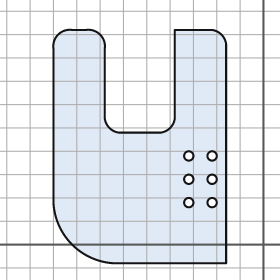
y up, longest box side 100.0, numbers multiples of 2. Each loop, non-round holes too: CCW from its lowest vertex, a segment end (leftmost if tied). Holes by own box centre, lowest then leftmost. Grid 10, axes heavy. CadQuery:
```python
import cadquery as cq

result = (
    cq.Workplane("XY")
    .moveTo(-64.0, -8.0)
    .lineTo(-16.0, -8.0)
    .lineTo(-16.0, 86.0)
    .threePointArc((-18.0, 90.0), (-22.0, 92.0))
    .lineTo(-38.0, 92.0)
    .lineTo(-38.0, 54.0)
    .threePointArc((-40.0, 50.0), (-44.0, 48.0))
    .lineTo(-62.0, 48.0)
    .threePointArc((-66.0, 50.0), (-68.0, 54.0))
    .lineTo(-68.0, 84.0)
    .threePointArc((-70.0, 90.0), (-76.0, 92.0))
    .lineTo(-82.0, 92.0)
    .threePointArc((-88.0, 90.0), (-90.0, 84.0))
    .lineTo(-90.0, 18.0)
    .threePointArc((-82.0, 0.0), (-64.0, -8.0))
    .close()
    .moveTo(-32.0, 18.0)
    .circle(2.0)
    .moveTo(-22.0, 18.0)
    .circle(2.0)
    .moveTo(-32.0, 28.0)
    .circle(2.0)
    .moveTo(-22.0, 28.0)
    .circle(2.0)
    .moveTo(-32.0, 38.0)
    .circle(2.0)
    .moveTo(-22.0, 38.0)
    .circle(2.0)
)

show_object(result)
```